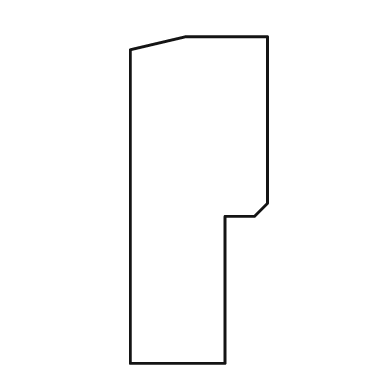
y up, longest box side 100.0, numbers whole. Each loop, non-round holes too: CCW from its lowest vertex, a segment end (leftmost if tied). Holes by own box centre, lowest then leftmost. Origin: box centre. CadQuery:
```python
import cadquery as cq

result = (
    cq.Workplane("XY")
    .moveTo(-21.0, -50.0)
    .lineTo(8.0, -50.0)
    .lineTo(8.0, -5.0)
    .lineTo(17.0, -5.0)
    .lineTo(21.0, -1.0)
    .lineTo(21.0, 50.0)
    .lineTo(-4.0, 50.0)
    .lineTo(-21.0, 46.0)
    .close()
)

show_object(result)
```